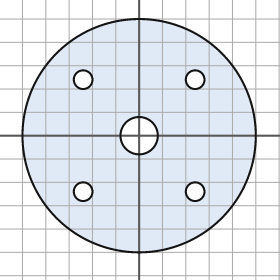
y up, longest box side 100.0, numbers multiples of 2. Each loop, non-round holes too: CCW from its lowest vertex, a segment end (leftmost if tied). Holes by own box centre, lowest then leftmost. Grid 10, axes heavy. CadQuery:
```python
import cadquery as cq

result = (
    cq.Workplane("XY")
    .moveTo(0.0, 0.0)
    .circle(50.0)
    .moveTo(-24.0, -24.0)
    .circle(4.0)
    .moveTo(24.0, -24.0)
    .circle(4.0)
    .moveTo(0.0, 0.0)
    .circle(8.0)
    .moveTo(-24.0, 24.0)
    .circle(4.0)
    .moveTo(24.0, 24.0)
    .circle(4.0)
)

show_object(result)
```